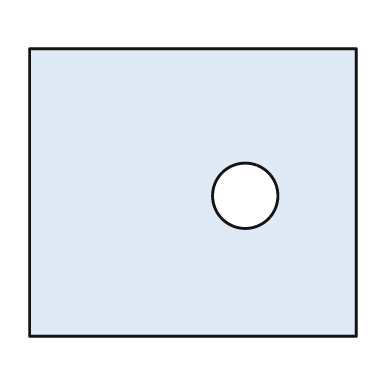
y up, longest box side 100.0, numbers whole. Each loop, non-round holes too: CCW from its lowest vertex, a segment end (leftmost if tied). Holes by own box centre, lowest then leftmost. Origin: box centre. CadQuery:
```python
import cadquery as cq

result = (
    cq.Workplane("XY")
    .moveTo(-50.0, -44.0)
    .lineTo(50.0, -44.0)
    .lineTo(50.0, 44.0)
    .lineTo(-50.0, 44.0)
    .close()
    .moveTo(16.0, -1.0)
    .circle(10.0)
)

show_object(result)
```